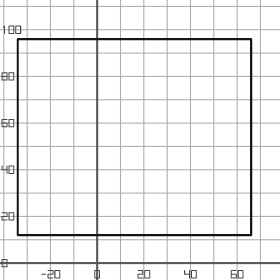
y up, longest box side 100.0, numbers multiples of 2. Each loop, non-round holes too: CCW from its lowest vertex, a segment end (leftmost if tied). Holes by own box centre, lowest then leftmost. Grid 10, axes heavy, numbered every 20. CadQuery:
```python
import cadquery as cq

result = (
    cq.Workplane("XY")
    .moveTo(-34.0, 12.0)
    .lineTo(66.0, 12.0)
    .lineTo(66.0, 96.0)
    .lineTo(-34.0, 96.0)
    .close()
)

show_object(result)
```